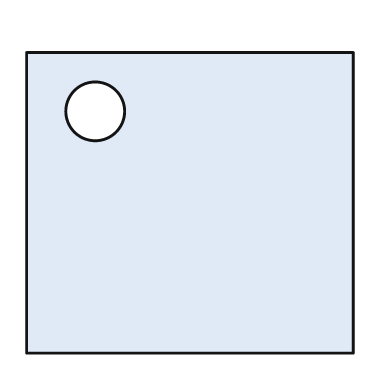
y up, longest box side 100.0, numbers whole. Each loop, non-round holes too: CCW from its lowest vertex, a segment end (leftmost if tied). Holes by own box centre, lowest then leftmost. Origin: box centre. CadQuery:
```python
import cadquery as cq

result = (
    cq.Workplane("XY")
    .moveTo(-50.0, -46.0)
    .lineTo(50.0, -46.0)
    .lineTo(50.0, 46.0)
    .lineTo(-50.0, 46.0)
    .close()
    .moveTo(-29.0, 28.0)
    .circle(9.0)
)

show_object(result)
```